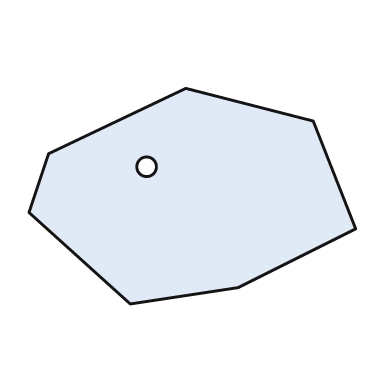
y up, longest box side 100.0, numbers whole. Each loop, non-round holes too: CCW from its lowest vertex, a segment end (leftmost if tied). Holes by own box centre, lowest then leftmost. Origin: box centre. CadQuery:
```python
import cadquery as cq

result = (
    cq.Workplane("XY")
    .moveTo(-19.0, -33.0)
    .lineTo(14.0, -28.0)
    .lineTo(50.0, -10.0)
    .lineTo(37.0, 23.0)
    .lineTo(-2.0, 33.0)
    .lineTo(-44.0, 13.0)
    .lineTo(-50.0, -5.0)
    .close()
    .moveTo(-14.0, 9.0)
    .circle(3.0)
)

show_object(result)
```